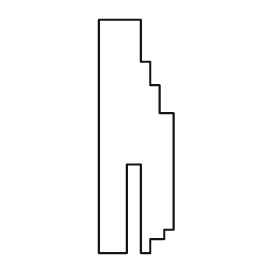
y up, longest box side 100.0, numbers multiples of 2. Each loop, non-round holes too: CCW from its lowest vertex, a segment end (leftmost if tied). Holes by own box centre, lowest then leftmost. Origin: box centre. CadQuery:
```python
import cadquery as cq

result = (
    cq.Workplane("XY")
    .moveTo(-16.0, -50.0)
    .lineTo(-4.0, -50.0)
    .lineTo(-4.0, -12.0)
    .lineTo(2.0, -12.0)
    .lineTo(2.0, -50.0)
    .lineTo(6.0, -50.0)
    .lineTo(6.0, -44.0)
    .lineTo(12.0, -44.0)
    .lineTo(12.0, -40.0)
    .lineTo(16.0, -40.0)
    .lineTo(16.0, 10.0)
    .lineTo(10.0, 10.0)
    .lineTo(10.0, 22.0)
    .lineTo(6.0, 22.0)
    .lineTo(6.0, 32.0)
    .lineTo(2.0, 32.0)
    .lineTo(2.0, 50.0)
    .lineTo(-16.0, 50.0)
    .close()
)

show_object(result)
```